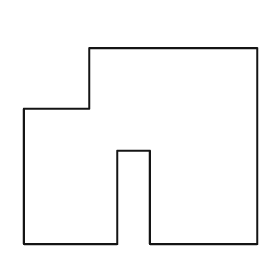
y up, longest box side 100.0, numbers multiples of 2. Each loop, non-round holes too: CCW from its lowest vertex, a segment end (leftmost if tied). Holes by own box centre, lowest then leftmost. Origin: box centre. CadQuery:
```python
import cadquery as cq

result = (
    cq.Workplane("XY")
    .moveTo(-50.0, -42.0)
    .lineTo(-10.0, -42.0)
    .lineTo(-10.0, -2.0)
    .lineTo(4.0, -2.0)
    .lineTo(4.0, -42.0)
    .lineTo(50.0, -42.0)
    .lineTo(50.0, 42.0)
    .lineTo(-22.0, 42.0)
    .lineTo(-22.0, 16.0)
    .lineTo(-50.0, 16.0)
    .close()
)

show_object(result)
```